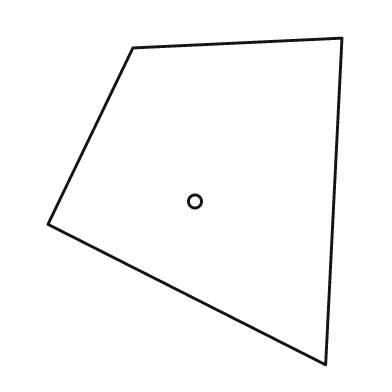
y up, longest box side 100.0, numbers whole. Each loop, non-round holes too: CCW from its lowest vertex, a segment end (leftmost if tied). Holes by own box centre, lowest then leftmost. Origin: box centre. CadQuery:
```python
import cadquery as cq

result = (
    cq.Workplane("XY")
    .moveTo(40.0, -50.0)
    .lineTo(45.0, 50.0)
    .lineTo(-19.0, 47.0)
    .lineTo(-45.0, -7.0)
    .close()
    .moveTo(0.0, 0.0)
    .circle(2.0)
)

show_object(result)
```